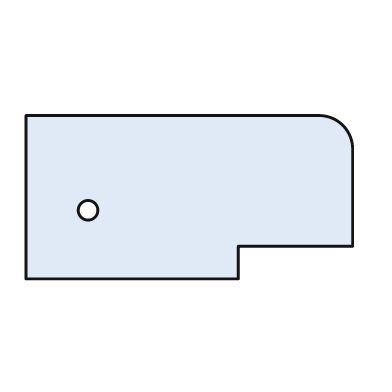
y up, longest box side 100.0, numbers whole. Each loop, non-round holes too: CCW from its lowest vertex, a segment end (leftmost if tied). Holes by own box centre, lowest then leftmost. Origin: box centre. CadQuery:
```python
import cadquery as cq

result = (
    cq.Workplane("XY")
    .moveTo(-50.0, -25.0)
    .lineTo(15.0, -25.0)
    .lineTo(15.0, -15.0)
    .lineTo(50.0, -15.0)
    .lineTo(50.0, 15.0)
    .threePointArc((47.0, 22.0), (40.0, 25.0))
    .lineTo(-50.0, 25.0)
    .close()
    .moveTo(-31.0, -4.0)
    .circle(3.0)
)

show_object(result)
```